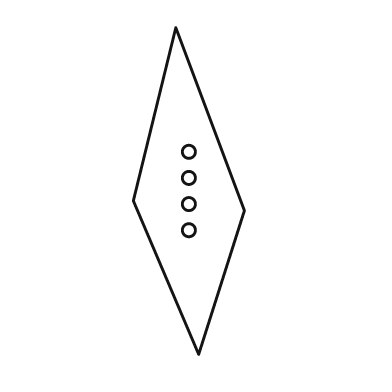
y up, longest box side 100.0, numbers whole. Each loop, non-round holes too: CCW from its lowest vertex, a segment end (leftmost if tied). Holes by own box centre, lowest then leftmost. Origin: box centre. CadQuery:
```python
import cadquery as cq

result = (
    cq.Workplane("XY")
    .moveTo(3.0, -50.0)
    .lineTo(17.0, -6.0)
    .lineTo(-4.0, 50.0)
    .lineTo(-17.0, -3.0)
    .close()
    .moveTo(0.0, -12.0)
    .circle(2.0)
    .moveTo(0.0, -4.0)
    .circle(2.0)
    .moveTo(0.0, 4.0)
    .circle(2.0)
    .moveTo(0.0, 12.0)
    .circle(2.0)
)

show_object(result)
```